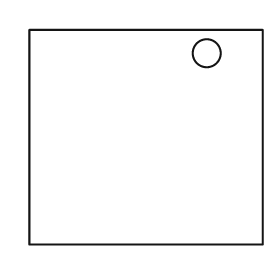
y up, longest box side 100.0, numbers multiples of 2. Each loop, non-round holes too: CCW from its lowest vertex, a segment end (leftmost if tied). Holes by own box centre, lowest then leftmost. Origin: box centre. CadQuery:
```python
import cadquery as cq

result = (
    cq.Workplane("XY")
    .moveTo(-50.0, -46.0)
    .lineTo(50.0, -46.0)
    .lineTo(50.0, 46.0)
    .lineTo(-50.0, 46.0)
    .close()
    .moveTo(26.0, 36.0)
    .circle(6.0)
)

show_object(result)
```